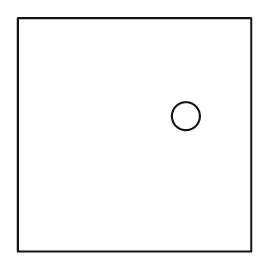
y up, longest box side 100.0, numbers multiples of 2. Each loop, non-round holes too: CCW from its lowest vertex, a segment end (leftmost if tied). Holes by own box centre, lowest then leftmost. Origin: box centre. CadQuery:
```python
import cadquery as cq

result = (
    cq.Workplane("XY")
    .moveTo(-50.0, -50.0)
    .lineTo(50.0, -50.0)
    .lineTo(50.0, 50.0)
    .lineTo(-50.0, 50.0)
    .close()
    .moveTo(22.0, 8.0)
    .circle(6.0)
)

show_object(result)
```